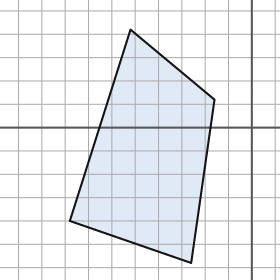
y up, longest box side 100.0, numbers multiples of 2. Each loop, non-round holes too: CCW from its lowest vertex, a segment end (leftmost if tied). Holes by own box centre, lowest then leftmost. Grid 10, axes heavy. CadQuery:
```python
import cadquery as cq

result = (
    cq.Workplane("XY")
    .moveTo(-26.0, -58.0)
    .lineTo(-16.0, 12.0)
    .lineTo(-52.0, 42.0)
    .lineTo(-78.0, -40.0)
    .close()
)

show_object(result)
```